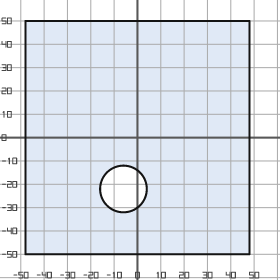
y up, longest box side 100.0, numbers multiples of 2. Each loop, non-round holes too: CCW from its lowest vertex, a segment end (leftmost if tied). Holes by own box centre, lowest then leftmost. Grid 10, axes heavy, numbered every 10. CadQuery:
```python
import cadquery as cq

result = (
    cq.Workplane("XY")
    .moveTo(-48.0, -50.0)
    .lineTo(48.0, -50.0)
    .lineTo(48.0, 50.0)
    .lineTo(-48.0, 50.0)
    .close()
    .moveTo(-6.0, -22.0)
    .circle(10.0)
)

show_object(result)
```